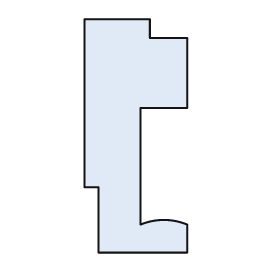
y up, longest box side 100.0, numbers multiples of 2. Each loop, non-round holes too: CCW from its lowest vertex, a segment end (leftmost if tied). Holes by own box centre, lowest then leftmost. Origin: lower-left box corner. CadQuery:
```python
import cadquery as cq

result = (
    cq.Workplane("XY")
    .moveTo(6.0, 0.0)
    .lineTo(44.0, 0.0)
    .lineTo(44.0, 12.0)
    .threePointArc((34.0, 14.0), (24.0, 12.0))
    .lineTo(24.0, 62.0)
    .lineTo(44.0, 62.0)
    .lineTo(44.0, 92.0)
    .lineTo(28.0, 92.0)
    .lineTo(28.0, 100.0)
    .lineTo(0.0, 100.0)
    .lineTo(0.0, 28.0)
    .lineTo(6.0, 28.0)
    .close()
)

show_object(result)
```